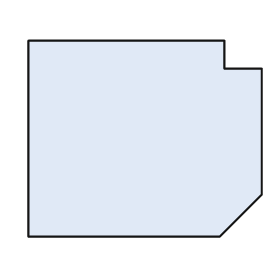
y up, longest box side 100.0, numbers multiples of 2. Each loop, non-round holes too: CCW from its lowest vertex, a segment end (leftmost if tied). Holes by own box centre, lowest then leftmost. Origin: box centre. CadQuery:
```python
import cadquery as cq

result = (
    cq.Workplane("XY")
    .moveTo(-50.0, -42.0)
    .lineTo(32.0, -42.0)
    .lineTo(50.0, -24.0)
    .lineTo(50.0, 30.0)
    .lineTo(34.0, 30.0)
    .lineTo(34.0, 42.0)
    .lineTo(-50.0, 42.0)
    .close()
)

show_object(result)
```